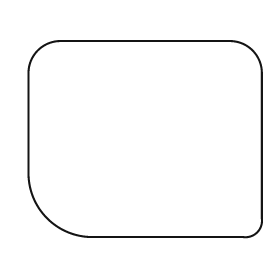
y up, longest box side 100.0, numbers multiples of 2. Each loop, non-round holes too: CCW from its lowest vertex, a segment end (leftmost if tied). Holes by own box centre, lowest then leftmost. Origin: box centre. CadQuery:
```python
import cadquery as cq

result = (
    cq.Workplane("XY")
    .moveTo(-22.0, -42.0)
    .lineTo(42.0, -42.0)
    .threePointArc((48.0, -40.0), (50.0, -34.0))
    .lineTo(50.0, 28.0)
    .threePointArc((46.0, 38.0), (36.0, 42.0))
    .lineTo(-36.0, 42.0)
    .threePointArc((-46.0, 38.0), (-50.0, 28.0))
    .lineTo(-50.0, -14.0)
    .threePointArc((-42.0, -34.0), (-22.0, -42.0))
    .close()
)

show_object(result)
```